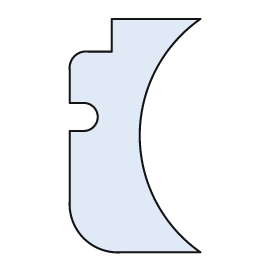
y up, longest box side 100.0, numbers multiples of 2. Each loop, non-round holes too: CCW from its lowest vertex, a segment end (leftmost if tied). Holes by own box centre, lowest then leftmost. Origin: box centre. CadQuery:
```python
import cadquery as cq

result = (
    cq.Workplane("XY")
    .moveTo(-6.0, -50.0)
    .lineTo(28.0, -50.0)
    .threePointArc((2.0, 0.0), (28.0, 50.0))
    .lineTo(-10.0, 50.0)
    .lineTo(-10.0, 36.0)
    .lineTo(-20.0, 36.0)
    .threePointArc((-26.0, 34.0), (-28.0, 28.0))
    .lineTo(-28.0, 14.0)
    .lineTo(-22.0, 14.0)
    .threePointArc((-16.0, 8.0), (-22.0, 2.0))
    .lineTo(-28.0, 2.0)
    .lineTo(-28.0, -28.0)
    .threePointArc((-22.0, -44.0), (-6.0, -50.0))
    .close()
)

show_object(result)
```